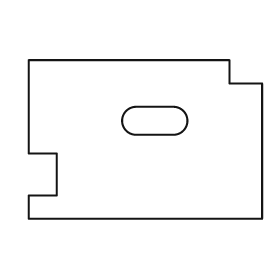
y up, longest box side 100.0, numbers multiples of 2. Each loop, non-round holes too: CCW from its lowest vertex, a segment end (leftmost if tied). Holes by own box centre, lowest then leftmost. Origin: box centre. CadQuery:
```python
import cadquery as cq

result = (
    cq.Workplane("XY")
    .moveTo(-50.0, -34.0)
    .lineTo(50.0, -34.0)
    .lineTo(50.0, 24.0)
    .lineTo(36.0, 24.0)
    .lineTo(36.0, 34.0)
    .lineTo(-50.0, 34.0)
    .lineTo(-50.0, -6.0)
    .lineTo(-38.0, -6.0)
    .lineTo(-38.0, -24.0)
    .lineTo(-50.0, -24.0)
    .close()
    .moveTo(-4.0, 2.0)
    .lineTo(12.0, 2.0)
    .threePointArc((18.0, 8.0), (12.0, 14.0))
    .lineTo(-4.0, 14.0)
    .threePointArc((-10.0, 8.0), (-4.0, 2.0))
    .close()
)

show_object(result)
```